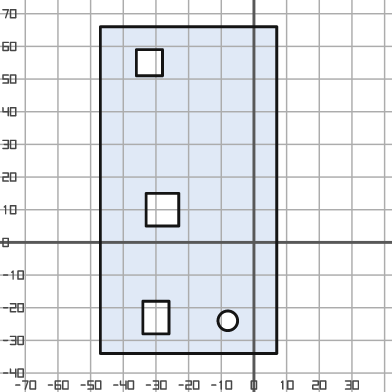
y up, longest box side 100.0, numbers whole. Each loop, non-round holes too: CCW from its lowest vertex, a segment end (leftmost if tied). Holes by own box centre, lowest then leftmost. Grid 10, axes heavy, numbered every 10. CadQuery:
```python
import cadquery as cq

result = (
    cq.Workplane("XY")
    .moveTo(-47.0, -34.0)
    .lineTo(7.0, -34.0)
    .lineTo(7.0, 66.0)
    .lineTo(-47.0, 66.0)
    .close()
    .moveTo(-8.0, -24.0)
    .circle(3.0)
    .moveTo(-34.0, -28.0)
    .lineTo(-26.0, -28.0)
    .lineTo(-26.0, -18.0)
    .lineTo(-34.0, -18.0)
    .close()
    .moveTo(-33.0, 5.0)
    .lineTo(-23.0, 5.0)
    .lineTo(-23.0, 15.0)
    .lineTo(-33.0, 15.0)
    .close()
    .moveTo(-36.0, 51.0)
    .lineTo(-28.0, 51.0)
    .lineTo(-28.0, 59.0)
    .lineTo(-36.0, 59.0)
    .close()
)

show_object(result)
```